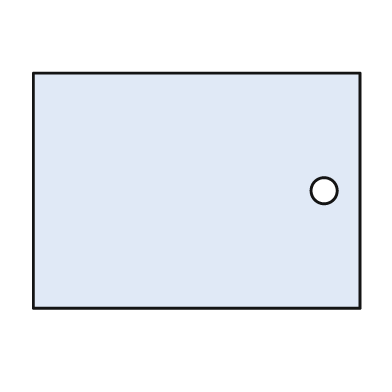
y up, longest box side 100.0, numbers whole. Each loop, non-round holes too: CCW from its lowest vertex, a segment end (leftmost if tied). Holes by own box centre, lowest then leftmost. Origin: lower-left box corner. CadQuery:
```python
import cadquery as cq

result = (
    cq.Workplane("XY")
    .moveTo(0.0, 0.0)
    .lineTo(100.0, 0.0)
    .lineTo(100.0, 72.0)
    .lineTo(0.0, 72.0)
    .close()
    .moveTo(89.0, 36.0)
    .circle(4.0)
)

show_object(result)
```